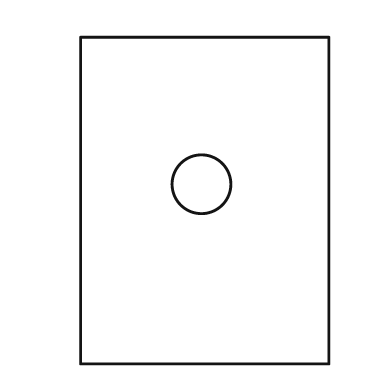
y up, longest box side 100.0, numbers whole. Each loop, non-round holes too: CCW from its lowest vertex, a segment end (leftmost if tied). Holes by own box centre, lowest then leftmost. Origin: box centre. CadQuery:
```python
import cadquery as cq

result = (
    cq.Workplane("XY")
    .moveTo(-38.0, -50.0)
    .lineTo(38.0, -50.0)
    .lineTo(38.0, 50.0)
    .lineTo(-38.0, 50.0)
    .close()
    .moveTo(-1.0, 5.0)
    .circle(9.0)
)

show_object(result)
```